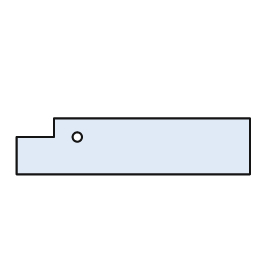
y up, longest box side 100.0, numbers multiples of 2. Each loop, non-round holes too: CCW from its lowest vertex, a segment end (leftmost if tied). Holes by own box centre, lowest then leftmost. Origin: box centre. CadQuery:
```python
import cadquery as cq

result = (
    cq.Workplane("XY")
    .moveTo(-50.0, -12.0)
    .lineTo(50.0, -12.0)
    .lineTo(50.0, 12.0)
    .lineTo(-34.0, 12.0)
    .lineTo(-34.0, 4.0)
    .lineTo(-50.0, 4.0)
    .close()
    .moveTo(-24.0, 4.0)
    .circle(2.0)
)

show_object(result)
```